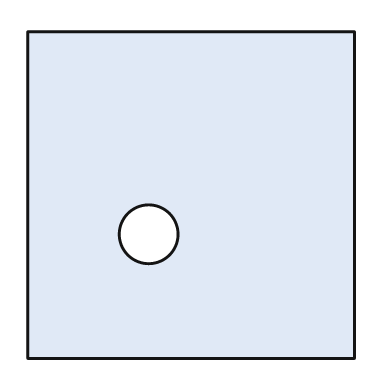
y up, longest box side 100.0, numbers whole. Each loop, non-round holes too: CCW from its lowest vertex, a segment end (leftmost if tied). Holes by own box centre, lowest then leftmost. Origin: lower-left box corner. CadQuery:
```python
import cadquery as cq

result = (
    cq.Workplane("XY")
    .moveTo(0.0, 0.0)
    .lineTo(100.0, 0.0)
    .lineTo(100.0, 100.0)
    .lineTo(0.0, 100.0)
    .close()
    .moveTo(37.0, 38.0)
    .circle(9.0)
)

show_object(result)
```